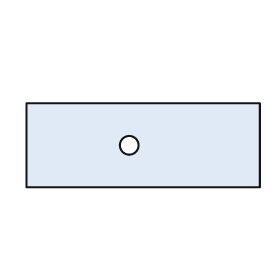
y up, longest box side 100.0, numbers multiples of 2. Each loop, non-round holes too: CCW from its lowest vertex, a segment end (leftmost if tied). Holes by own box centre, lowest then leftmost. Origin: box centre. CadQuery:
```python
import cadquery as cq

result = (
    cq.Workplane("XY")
    .moveTo(-50.0, -18.0)
    .lineTo(50.0, -18.0)
    .lineTo(50.0, 18.0)
    .lineTo(-50.0, 18.0)
    .close()
    .moveTo(-6.0, 0.0)
    .circle(4.0)
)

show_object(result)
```